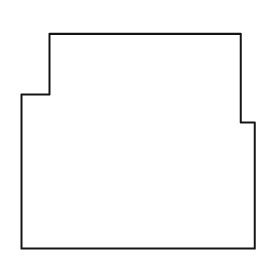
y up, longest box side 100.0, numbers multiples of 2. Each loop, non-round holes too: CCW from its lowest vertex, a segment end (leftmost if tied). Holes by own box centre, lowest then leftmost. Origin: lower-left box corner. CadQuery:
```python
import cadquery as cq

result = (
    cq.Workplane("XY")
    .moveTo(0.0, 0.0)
    .lineTo(100.0, 0.0)
    .lineTo(100.0, 54.0)
    .lineTo(94.0, 54.0)
    .lineTo(94.0, 92.0)
    .lineTo(12.0, 92.0)
    .lineTo(12.0, 66.0)
    .lineTo(0.0, 66.0)
    .close()
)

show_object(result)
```